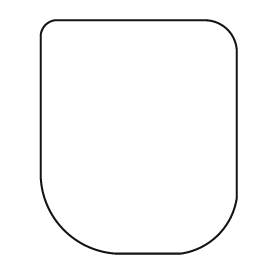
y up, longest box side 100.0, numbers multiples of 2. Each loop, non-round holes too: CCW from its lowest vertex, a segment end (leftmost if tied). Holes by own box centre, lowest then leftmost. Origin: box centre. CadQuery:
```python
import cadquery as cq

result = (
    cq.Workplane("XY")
    .moveTo(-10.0, -50.0)
    .lineTo(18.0, -50.0)
    .threePointArc((34.0, -42.0), (42.0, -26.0))
    .lineTo(42.0, 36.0)
    .threePointArc((38.0, 46.0), (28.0, 50.0))
    .lineTo(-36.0, 50.0)
    .threePointArc((-40.0, 48.0), (-42.0, 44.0))
    .lineTo(-42.0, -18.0)
    .threePointArc((-32.0, -40.0), (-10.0, -50.0))
    .close()
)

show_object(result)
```